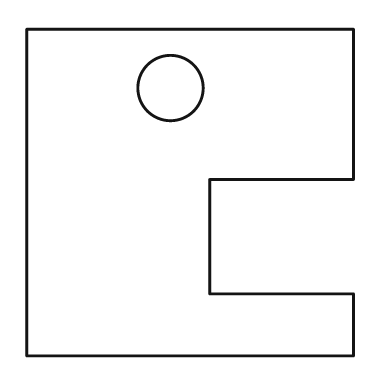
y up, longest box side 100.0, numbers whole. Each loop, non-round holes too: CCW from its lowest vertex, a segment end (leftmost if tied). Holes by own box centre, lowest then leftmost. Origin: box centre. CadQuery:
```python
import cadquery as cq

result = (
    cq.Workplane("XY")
    .moveTo(-50.0, -50.0)
    .lineTo(50.0, -50.0)
    .lineTo(50.0, -31.0)
    .lineTo(6.0, -31.0)
    .lineTo(6.0, 4.0)
    .lineTo(50.0, 4.0)
    .lineTo(50.0, 50.0)
    .lineTo(-50.0, 50.0)
    .close()
    .moveTo(-6.0, 32.0)
    .circle(10.0)
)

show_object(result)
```